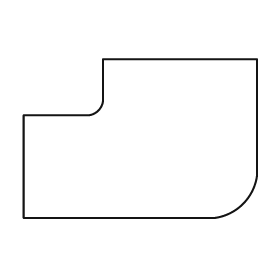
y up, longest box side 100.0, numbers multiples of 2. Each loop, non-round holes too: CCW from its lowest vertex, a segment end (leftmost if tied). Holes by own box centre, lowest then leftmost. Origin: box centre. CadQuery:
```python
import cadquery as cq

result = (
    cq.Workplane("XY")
    .moveTo(-50.0, -34.0)
    .lineTo(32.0, -34.0)
    .threePointArc((44.0, -28.0), (50.0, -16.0))
    .lineTo(50.0, 34.0)
    .lineTo(-16.0, 34.0)
    .lineTo(-16.0, 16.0)
    .threePointArc((-18.0, 12.0), (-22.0, 10.0))
    .lineTo(-50.0, 10.0)
    .close()
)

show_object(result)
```